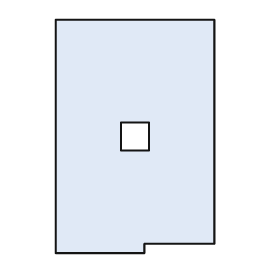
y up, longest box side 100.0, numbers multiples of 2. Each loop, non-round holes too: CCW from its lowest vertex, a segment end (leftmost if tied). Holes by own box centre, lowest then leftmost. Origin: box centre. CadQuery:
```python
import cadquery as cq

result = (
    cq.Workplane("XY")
    .moveTo(-34.0, -50.0)
    .lineTo(4.0, -50.0)
    .lineTo(4.0, -46.0)
    .lineTo(34.0, -46.0)
    .lineTo(34.0, 50.0)
    .lineTo(-34.0, 50.0)
    .close()
    .moveTo(-6.0, -6.0)
    .lineTo(6.0, -6.0)
    .lineTo(6.0, 6.0)
    .lineTo(-6.0, 6.0)
    .close()
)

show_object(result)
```